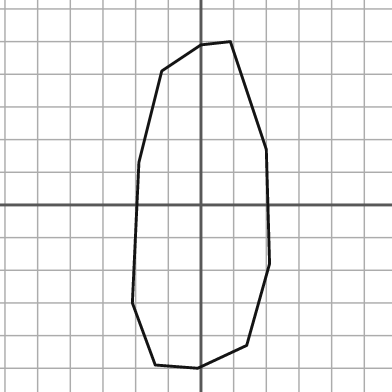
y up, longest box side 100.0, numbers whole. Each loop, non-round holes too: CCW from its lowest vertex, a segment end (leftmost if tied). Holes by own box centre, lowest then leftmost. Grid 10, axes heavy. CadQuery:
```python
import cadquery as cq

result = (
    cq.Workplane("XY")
    .moveTo(-1.0, -50.0)
    .lineTo(14.0, -43.0)
    .lineTo(21.0, -18.0)
    .lineTo(20.0, 17.0)
    .lineTo(9.0, 50.0)
    .lineTo(0.0, 49.0)
    .lineTo(-12.0, 41.0)
    .lineTo(-19.0, 13.0)
    .lineTo(-21.0, -30.0)
    .lineTo(-14.0, -49.0)
    .close()
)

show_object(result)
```